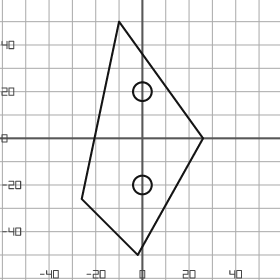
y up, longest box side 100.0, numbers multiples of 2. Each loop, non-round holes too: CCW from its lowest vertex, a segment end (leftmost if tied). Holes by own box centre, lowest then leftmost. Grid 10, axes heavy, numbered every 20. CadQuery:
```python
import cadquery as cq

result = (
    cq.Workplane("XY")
    .moveTo(-2.0, -50.0)
    .lineTo(26.0, 0.0)
    .lineTo(-10.0, 50.0)
    .lineTo(-26.0, -26.0)
    .close()
    .moveTo(0.0, -20.0)
    .circle(4.0)
    .moveTo(0.0, 20.0)
    .circle(4.0)
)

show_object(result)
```